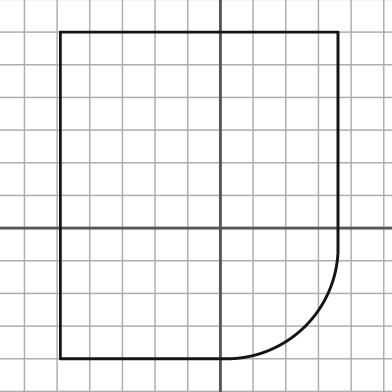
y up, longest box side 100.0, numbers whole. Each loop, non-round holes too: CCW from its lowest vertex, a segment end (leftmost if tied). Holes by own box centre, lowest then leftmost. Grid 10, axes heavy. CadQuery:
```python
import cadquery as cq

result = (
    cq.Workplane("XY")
    .moveTo(-49.0, -40.0)
    .lineTo(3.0, -40.0)
    .threePointArc((26.0, -30.0), (36.0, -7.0))
    .lineTo(36.0, 60.0)
    .lineTo(-49.0, 60.0)
    .close()
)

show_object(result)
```